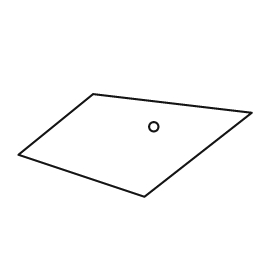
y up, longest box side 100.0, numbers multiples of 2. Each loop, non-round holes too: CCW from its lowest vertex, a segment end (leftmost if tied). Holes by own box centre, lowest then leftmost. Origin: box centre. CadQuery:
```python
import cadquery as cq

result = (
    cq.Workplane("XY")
    .moveTo(4.0, -22.0)
    .lineTo(50.0, 14.0)
    .lineTo(-18.0, 22.0)
    .lineTo(-50.0, -4.0)
    .close()
    .moveTo(8.0, 8.0)
    .circle(2.0)
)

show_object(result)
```